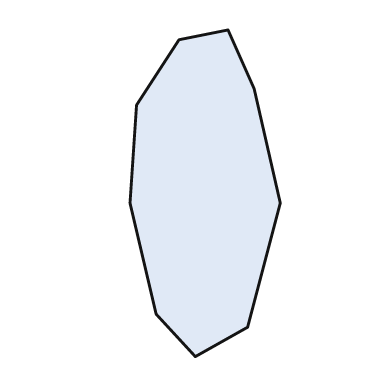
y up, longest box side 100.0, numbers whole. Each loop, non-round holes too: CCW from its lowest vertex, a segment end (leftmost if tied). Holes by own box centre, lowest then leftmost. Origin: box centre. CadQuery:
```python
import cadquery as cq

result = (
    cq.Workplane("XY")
    .moveTo(-3.0, -50.0)
    .lineTo(13.0, -41.0)
    .lineTo(23.0, -3.0)
    .lineTo(15.0, 32.0)
    .lineTo(7.0, 50.0)
    .lineTo(-8.0, 47.0)
    .lineTo(-21.0, 27.0)
    .lineTo(-23.0, -3.0)
    .lineTo(-15.0, -37.0)
    .close()
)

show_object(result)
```